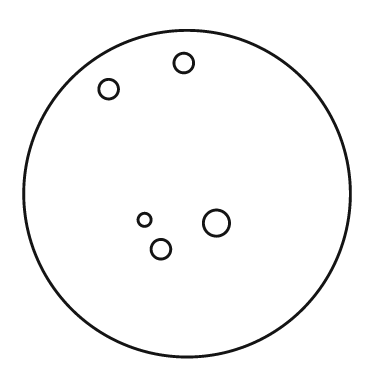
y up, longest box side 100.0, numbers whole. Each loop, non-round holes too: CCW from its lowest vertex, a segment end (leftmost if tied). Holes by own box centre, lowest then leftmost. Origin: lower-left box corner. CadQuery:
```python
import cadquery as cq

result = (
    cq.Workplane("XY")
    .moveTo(50.0, 50.0)
    .circle(50.0)
    .moveTo(42.0, 33.0)
    .circle(3.0)
    .moveTo(59.0, 41.0)
    .circle(4.0)
    .moveTo(37.0, 42.0)
    .circle(2.0)
    .moveTo(26.0, 82.0)
    .circle(3.0)
    .moveTo(49.0, 90.0)
    .circle(3.0)
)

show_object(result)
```